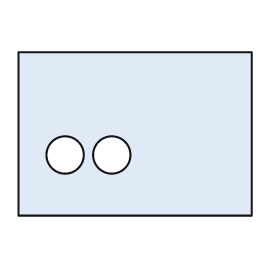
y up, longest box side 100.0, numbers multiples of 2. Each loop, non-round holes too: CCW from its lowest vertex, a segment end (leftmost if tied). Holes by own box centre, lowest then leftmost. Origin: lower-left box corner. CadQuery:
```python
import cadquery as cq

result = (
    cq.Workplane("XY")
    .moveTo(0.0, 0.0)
    .lineTo(100.0, 0.0)
    .lineTo(100.0, 70.0)
    .lineTo(0.0, 70.0)
    .close()
    .moveTo(20.0, 26.0)
    .circle(8.0)
    .moveTo(40.0, 26.0)
    .circle(8.0)
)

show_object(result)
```